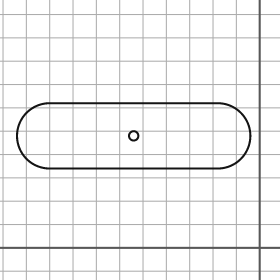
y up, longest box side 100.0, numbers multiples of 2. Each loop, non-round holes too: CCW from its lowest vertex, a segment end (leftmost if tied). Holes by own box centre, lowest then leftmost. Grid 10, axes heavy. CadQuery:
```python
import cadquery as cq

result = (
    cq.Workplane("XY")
    .moveTo(-90.0, 34.0)
    .lineTo(-18.0, 34.0)
    .threePointArc((-4.0, 48.0), (-18.0, 62.0))
    .lineTo(-90.0, 62.0)
    .threePointArc((-104.0, 48.0), (-90.0, 34.0))
    .close()
    .moveTo(-54.0, 48.0)
    .circle(2.0)
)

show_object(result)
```